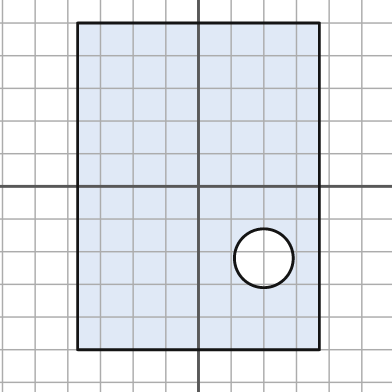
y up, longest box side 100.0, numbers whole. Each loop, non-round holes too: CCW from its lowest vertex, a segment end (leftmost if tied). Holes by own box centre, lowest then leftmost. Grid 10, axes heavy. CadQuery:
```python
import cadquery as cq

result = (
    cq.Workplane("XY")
    .moveTo(-37.0, -50.0)
    .lineTo(37.0, -50.0)
    .lineTo(37.0, 50.0)
    .lineTo(-37.0, 50.0)
    .close()
    .moveTo(20.0, -22.0)
    .circle(9.0)
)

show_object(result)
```